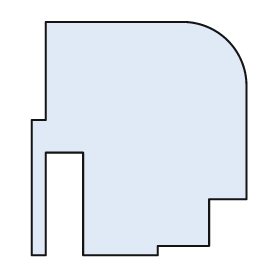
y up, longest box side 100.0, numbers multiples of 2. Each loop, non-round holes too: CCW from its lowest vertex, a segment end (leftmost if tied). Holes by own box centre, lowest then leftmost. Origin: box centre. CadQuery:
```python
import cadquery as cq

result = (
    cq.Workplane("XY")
    .moveTo(-46.0, -50.0)
    .lineTo(-40.0, -50.0)
    .lineTo(-40.0, -6.0)
    .lineTo(-24.0, -6.0)
    .lineTo(-24.0, -50.0)
    .lineTo(8.0, -50.0)
    .lineTo(8.0, -46.0)
    .lineTo(30.0, -46.0)
    .lineTo(30.0, -26.0)
    .lineTo(46.0, -26.0)
    .lineTo(46.0, 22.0)
    .threePointArc((38.0, 42.0), (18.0, 50.0))
    .lineTo(-40.0, 50.0)
    .lineTo(-40.0, 8.0)
    .lineTo(-46.0, 8.0)
    .close()
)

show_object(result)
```